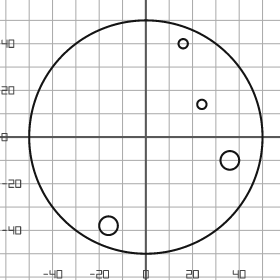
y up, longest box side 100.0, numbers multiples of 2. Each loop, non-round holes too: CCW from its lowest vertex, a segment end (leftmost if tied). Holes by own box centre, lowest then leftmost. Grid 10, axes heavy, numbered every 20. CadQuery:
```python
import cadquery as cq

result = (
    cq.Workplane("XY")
    .moveTo(0.0, 0.0)
    .circle(50.0)
    .moveTo(-16.0, -38.0)
    .circle(4.0)
    .moveTo(36.0, -10.0)
    .circle(4.0)
    .moveTo(24.0, 14.0)
    .circle(2.0)
    .moveTo(16.0, 40.0)
    .circle(2.0)
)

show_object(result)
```